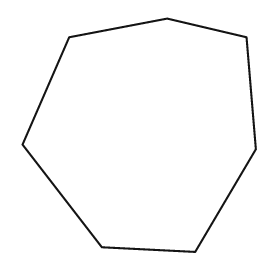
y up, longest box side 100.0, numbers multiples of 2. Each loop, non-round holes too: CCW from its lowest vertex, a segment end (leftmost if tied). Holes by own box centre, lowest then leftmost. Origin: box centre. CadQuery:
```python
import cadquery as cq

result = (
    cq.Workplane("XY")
    .moveTo(24.0, -50.0)
    .lineTo(50.0, -6.0)
    .lineTo(46.0, 42.0)
    .lineTo(12.0, 50.0)
    .lineTo(-30.0, 42.0)
    .lineTo(-50.0, -4.0)
    .lineTo(-16.0, -48.0)
    .close()
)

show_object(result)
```